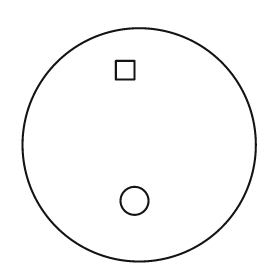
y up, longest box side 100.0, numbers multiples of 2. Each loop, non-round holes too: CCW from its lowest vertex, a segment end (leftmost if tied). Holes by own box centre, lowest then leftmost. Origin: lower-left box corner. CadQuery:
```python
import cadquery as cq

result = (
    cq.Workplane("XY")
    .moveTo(50.0, 50.0)
    .circle(50.0)
    .moveTo(48.0, 26.0)
    .circle(6.0)
    .moveTo(40.0, 78.0)
    .lineTo(48.0, 78.0)
    .lineTo(48.0, 86.0)
    .lineTo(40.0, 86.0)
    .close()
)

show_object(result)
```